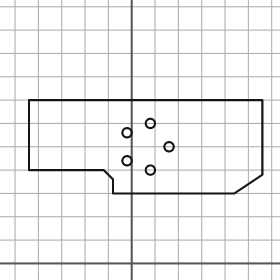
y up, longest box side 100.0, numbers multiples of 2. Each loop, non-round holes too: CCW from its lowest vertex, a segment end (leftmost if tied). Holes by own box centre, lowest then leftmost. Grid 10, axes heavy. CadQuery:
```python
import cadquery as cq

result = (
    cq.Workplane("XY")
    .moveTo(-8.0, 30.0)
    .lineTo(44.0, 30.0)
    .lineTo(56.0, 38.0)
    .lineTo(56.0, 70.0)
    .lineTo(-44.0, 70.0)
    .lineTo(-44.0, 40.0)
    .lineTo(-12.0, 40.0)
    .lineTo(-8.0, 36.0)
    .close()
    .moveTo(8.0, 40.0)
    .circle(2.0)
    .moveTo(-2.0, 44.0)
    .circle(2.0)
    .moveTo(16.0, 50.0)
    .circle(2.0)
    .moveTo(-2.0, 56.0)
    .circle(2.0)
    .moveTo(8.0, 60.0)
    .circle(2.0)
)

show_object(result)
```